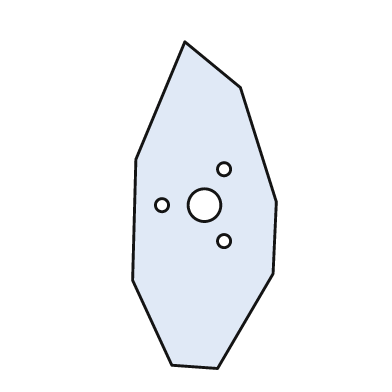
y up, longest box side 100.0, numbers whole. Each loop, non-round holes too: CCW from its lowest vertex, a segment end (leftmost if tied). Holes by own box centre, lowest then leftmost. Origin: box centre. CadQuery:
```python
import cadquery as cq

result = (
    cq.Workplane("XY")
    .moveTo(4.0, -50.0)
    .lineTo(21.0, -21.0)
    .lineTo(22.0, 1.0)
    .lineTo(11.0, 36.0)
    .lineTo(-6.0, 50.0)
    .lineTo(-21.0, 14.0)
    .lineTo(-22.0, -23.0)
    .lineTo(-10.0, -49.0)
    .close()
    .moveTo(6.0, -11.0)
    .circle(2.0)
    .moveTo(-13.0, 0.0)
    .circle(2.0)
    .moveTo(0.0, 0.0)
    .circle(5.0)
    .moveTo(6.0, 11.0)
    .circle(2.0)
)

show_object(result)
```